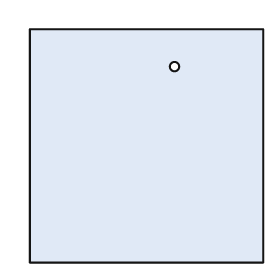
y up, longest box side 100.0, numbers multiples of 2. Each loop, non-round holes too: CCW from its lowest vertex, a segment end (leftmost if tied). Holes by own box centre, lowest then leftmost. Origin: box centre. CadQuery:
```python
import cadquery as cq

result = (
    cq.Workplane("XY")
    .moveTo(-50.0, -50.0)
    .lineTo(50.0, -50.0)
    .lineTo(50.0, 50.0)
    .lineTo(-50.0, 50.0)
    .close()
    .moveTo(12.0, 34.0)
    .circle(2.0)
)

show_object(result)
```